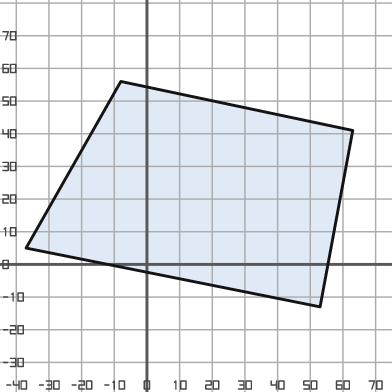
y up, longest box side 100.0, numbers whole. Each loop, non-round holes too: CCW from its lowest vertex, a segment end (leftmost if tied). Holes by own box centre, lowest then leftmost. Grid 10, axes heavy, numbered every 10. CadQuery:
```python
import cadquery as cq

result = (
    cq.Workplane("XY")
    .moveTo(53.0, -13.0)
    .lineTo(63.0, 41.0)
    .lineTo(-8.0, 56.0)
    .lineTo(-37.0, 5.0)
    .close()
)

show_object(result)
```